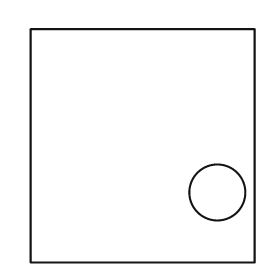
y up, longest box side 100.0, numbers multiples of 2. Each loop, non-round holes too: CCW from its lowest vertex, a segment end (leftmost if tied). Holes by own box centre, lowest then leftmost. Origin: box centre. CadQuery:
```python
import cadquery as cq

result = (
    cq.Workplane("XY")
    .moveTo(-48.0, -50.0)
    .lineTo(48.0, -50.0)
    .lineTo(48.0, 50.0)
    .lineTo(-48.0, 50.0)
    .close()
    .moveTo(32.0, -20.0)
    .circle(12.0)
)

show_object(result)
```